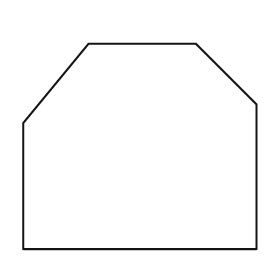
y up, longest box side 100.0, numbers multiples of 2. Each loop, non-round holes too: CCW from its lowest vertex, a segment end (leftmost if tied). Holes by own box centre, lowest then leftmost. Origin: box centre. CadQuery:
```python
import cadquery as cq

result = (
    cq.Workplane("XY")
    .moveTo(-50.0, -44.0)
    .lineTo(50.0, -44.0)
    .lineTo(50.0, 18.0)
    .lineTo(24.0, 44.0)
    .lineTo(-22.0, 44.0)
    .lineTo(-50.0, 10.0)
    .close()
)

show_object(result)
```